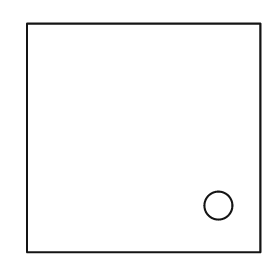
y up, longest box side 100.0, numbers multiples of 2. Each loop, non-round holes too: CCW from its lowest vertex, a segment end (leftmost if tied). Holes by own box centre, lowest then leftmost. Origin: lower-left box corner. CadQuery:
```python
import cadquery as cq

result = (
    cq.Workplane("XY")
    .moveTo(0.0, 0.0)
    .lineTo(100.0, 0.0)
    .lineTo(100.0, 98.0)
    .lineTo(0.0, 98.0)
    .close()
    .moveTo(82.0, 20.0)
    .circle(6.0)
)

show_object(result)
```